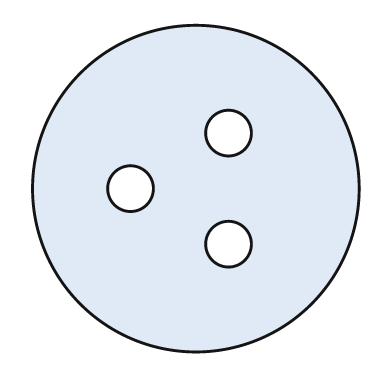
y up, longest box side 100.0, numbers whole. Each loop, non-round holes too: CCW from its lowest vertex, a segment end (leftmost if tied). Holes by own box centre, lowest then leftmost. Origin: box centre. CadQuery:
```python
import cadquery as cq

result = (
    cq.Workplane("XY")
    .moveTo(0.0, 0.0)
    .circle(50.0)
    .moveTo(10.0, -17.0)
    .circle(7.0)
    .moveTo(-20.0, 0.0)
    .circle(7.0)
    .moveTo(10.0, 17.0)
    .circle(7.0)
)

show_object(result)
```